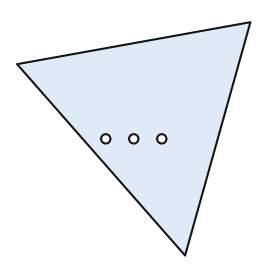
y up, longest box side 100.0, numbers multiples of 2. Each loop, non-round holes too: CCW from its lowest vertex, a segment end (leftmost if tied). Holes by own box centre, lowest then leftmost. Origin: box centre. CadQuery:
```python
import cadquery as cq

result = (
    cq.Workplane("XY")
    .moveTo(22.0, -50.0)
    .lineTo(50.0, 50.0)
    .lineTo(-50.0, 32.0)
    .close()
    .moveTo(-12.0, 0.0)
    .circle(2.0)
    .moveTo(0.0, 0.0)
    .circle(2.0)
    .moveTo(12.0, 0.0)
    .circle(2.0)
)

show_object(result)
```